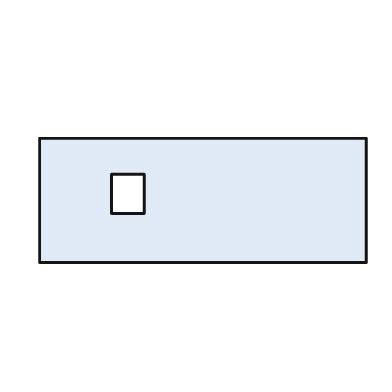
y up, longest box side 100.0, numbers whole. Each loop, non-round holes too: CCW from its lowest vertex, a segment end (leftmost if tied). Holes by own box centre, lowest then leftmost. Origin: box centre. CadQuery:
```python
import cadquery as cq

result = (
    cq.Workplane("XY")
    .moveTo(-50.0, -19.0)
    .lineTo(50.0, -19.0)
    .lineTo(50.0, 19.0)
    .lineTo(-50.0, 19.0)
    .close()
    .moveTo(-28.0, -4.0)
    .lineTo(-18.0, -4.0)
    .lineTo(-18.0, 8.0)
    .lineTo(-28.0, 8.0)
    .close()
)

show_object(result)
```